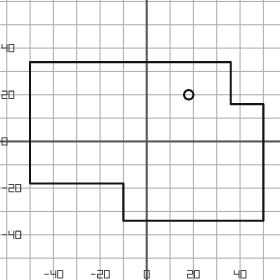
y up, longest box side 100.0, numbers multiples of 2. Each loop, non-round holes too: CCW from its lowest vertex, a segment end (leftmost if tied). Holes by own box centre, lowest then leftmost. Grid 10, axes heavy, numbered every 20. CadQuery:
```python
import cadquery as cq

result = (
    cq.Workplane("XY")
    .moveTo(-10.0, -34.0)
    .lineTo(50.0, -34.0)
    .lineTo(50.0, 16.0)
    .lineTo(36.0, 16.0)
    .lineTo(36.0, 34.0)
    .lineTo(-50.0, 34.0)
    .lineTo(-50.0, -18.0)
    .lineTo(-10.0, -18.0)
    .close()
    .moveTo(18.0, 20.0)
    .circle(2.0)
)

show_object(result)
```